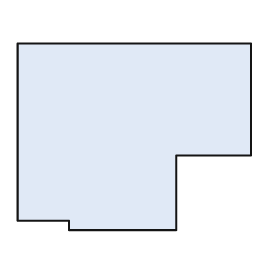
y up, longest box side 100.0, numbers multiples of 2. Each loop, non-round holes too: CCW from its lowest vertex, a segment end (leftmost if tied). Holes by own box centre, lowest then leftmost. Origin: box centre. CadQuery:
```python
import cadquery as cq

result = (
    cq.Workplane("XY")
    .moveTo(-28.0, -40.0)
    .lineTo(18.0, -40.0)
    .lineTo(18.0, -8.0)
    .lineTo(50.0, -8.0)
    .lineTo(50.0, 40.0)
    .lineTo(-50.0, 40.0)
    .lineTo(-50.0, -36.0)
    .lineTo(-28.0, -36.0)
    .close()
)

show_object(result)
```